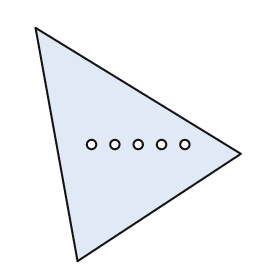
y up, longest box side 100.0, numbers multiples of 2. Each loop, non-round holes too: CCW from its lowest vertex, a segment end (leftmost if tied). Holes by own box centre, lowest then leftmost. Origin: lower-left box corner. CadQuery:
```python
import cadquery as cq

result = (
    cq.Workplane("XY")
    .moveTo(18.0, 0.0)
    .lineTo(88.0, 46.0)
    .lineTo(0.0, 100.0)
    .close()
    .moveTo(24.0, 50.0)
    .circle(2.0)
    .moveTo(34.0, 50.0)
    .circle(2.0)
    .moveTo(44.0, 50.0)
    .circle(2.0)
    .moveTo(54.0, 50.0)
    .circle(2.0)
    .moveTo(64.0, 50.0)
    .circle(2.0)
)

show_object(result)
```